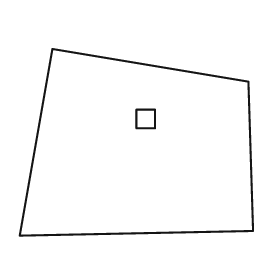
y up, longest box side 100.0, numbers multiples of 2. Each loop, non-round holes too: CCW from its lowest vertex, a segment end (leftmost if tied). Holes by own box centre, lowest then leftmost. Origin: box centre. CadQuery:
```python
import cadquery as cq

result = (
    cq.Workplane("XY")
    .moveTo(-50.0, -40.0)
    .lineTo(50.0, -38.0)
    .lineTo(48.0, 26.0)
    .lineTo(-36.0, 40.0)
    .close()
    .moveTo(0.0, 6.0)
    .lineTo(8.0, 6.0)
    .lineTo(8.0, 14.0)
    .lineTo(0.0, 14.0)
    .close()
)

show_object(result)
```